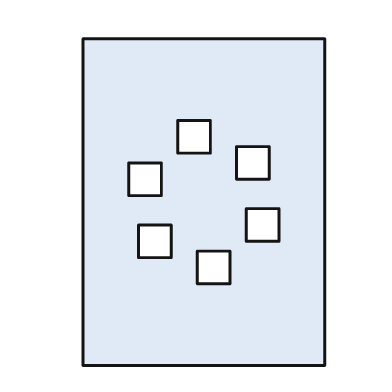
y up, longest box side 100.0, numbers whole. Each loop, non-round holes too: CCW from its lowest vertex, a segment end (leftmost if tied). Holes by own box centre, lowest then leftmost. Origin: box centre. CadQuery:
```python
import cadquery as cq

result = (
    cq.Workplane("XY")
    .moveTo(-37.0, -50.0)
    .lineTo(37.0, -50.0)
    .lineTo(37.0, 50.0)
    .lineTo(-37.0, 50.0)
    .close()
    .moveTo(-2.0, -25.0)
    .lineTo(8.0, -25.0)
    .lineTo(8.0, -15.0)
    .lineTo(-2.0, -15.0)
    .close()
    .moveTo(-20.0, -17.0)
    .lineTo(-10.0, -17.0)
    .lineTo(-10.0, -7.0)
    .lineTo(-20.0, -7.0)
    .close()
    .moveTo(13.0, -12.0)
    .lineTo(23.0, -12.0)
    .lineTo(23.0, -2.0)
    .lineTo(13.0, -2.0)
    .close()
    .moveTo(-23.0, 2.0)
    .lineTo(-13.0, 2.0)
    .lineTo(-13.0, 12.0)
    .lineTo(-23.0, 12.0)
    .close()
    .moveTo(10.0, 7.0)
    .lineTo(20.0, 7.0)
    .lineTo(20.0, 17.0)
    .lineTo(10.0, 17.0)
    .close()
    .moveTo(-8.0, 15.0)
    .lineTo(2.0, 15.0)
    .lineTo(2.0, 25.0)
    .lineTo(-8.0, 25.0)
    .close()
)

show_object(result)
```